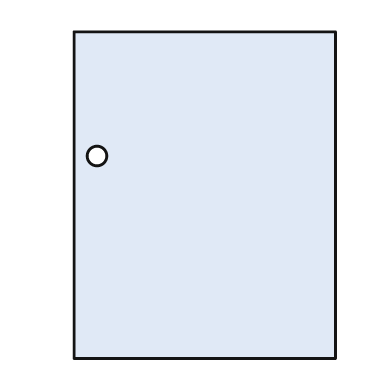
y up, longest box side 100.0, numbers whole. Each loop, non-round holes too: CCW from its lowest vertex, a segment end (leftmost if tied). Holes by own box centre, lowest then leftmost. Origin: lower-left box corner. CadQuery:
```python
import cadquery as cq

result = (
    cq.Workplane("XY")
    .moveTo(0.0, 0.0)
    .lineTo(80.0, 0.0)
    .lineTo(80.0, 100.0)
    .lineTo(0.0, 100.0)
    .close()
    .moveTo(7.0, 62.0)
    .circle(3.0)
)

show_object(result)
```